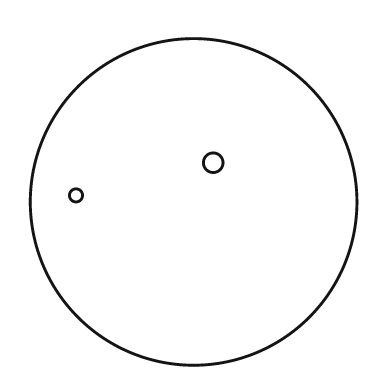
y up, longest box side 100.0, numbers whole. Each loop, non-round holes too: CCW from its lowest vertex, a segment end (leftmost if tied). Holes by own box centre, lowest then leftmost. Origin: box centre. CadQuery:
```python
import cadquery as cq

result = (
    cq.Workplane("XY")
    .moveTo(0.0, 0.0)
    .circle(50.0)
    .moveTo(-36.0, 2.0)
    .circle(2.0)
    .moveTo(6.0, 12.0)
    .circle(3.0)
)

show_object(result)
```